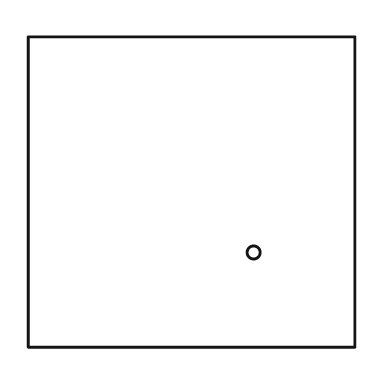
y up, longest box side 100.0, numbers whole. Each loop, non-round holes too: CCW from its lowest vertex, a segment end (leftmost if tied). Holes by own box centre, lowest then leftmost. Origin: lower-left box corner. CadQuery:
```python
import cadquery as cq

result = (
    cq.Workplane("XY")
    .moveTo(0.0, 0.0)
    .lineTo(100.0, 0.0)
    .lineTo(100.0, 95.0)
    .lineTo(0.0, 95.0)
    .close()
    .moveTo(69.0, 29.0)
    .circle(2.0)
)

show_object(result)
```